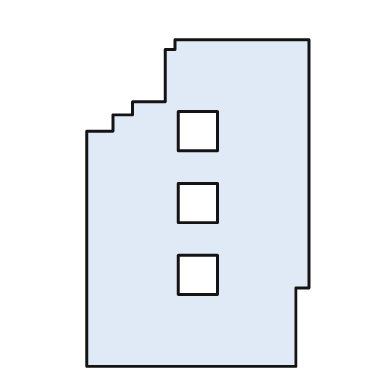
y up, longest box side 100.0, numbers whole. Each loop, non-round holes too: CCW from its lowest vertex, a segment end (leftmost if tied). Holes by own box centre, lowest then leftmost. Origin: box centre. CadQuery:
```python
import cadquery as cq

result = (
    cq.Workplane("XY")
    .moveTo(-34.0, -50.0)
    .lineTo(30.0, -50.0)
    .lineTo(30.0, -26.0)
    .lineTo(34.0, -26.0)
    .lineTo(34.0, 50.0)
    .lineTo(-7.0, 50.0)
    .lineTo(-7.0, 47.0)
    .lineTo(-10.0, 47.0)
    .lineTo(-10.0, 31.0)
    .lineTo(-20.0, 31.0)
    .lineTo(-20.0, 27.0)
    .lineTo(-26.0, 27.0)
    .lineTo(-26.0, 22.0)
    .lineTo(-34.0, 22.0)
    .close()
    .moveTo(-6.0, -28.0)
    .lineTo(6.0, -28.0)
    .lineTo(6.0, -16.0)
    .lineTo(-6.0, -16.0)
    .close()
    .moveTo(-6.0, -6.0)
    .lineTo(6.0, -6.0)
    .lineTo(6.0, 6.0)
    .lineTo(-6.0, 6.0)
    .close()
    .moveTo(-6.0, 16.0)
    .lineTo(6.0, 16.0)
    .lineTo(6.0, 28.0)
    .lineTo(-6.0, 28.0)
    .close()
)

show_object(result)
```